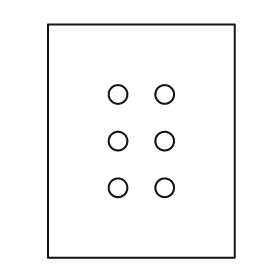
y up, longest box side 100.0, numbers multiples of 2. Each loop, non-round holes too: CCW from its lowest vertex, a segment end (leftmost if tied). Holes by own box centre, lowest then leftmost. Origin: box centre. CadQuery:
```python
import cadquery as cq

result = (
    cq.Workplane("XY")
    .moveTo(-40.0, -50.0)
    .lineTo(40.0, -50.0)
    .lineTo(40.0, 50.0)
    .lineTo(-40.0, 50.0)
    .close()
    .moveTo(-10.0, -20.0)
    .circle(4.0)
    .moveTo(10.0, -20.0)
    .circle(4.0)
    .moveTo(-10.0, 0.0)
    .circle(4.0)
    .moveTo(10.0, 0.0)
    .circle(4.0)
    .moveTo(-10.0, 20.0)
    .circle(4.0)
    .moveTo(10.0, 20.0)
    .circle(4.0)
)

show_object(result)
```